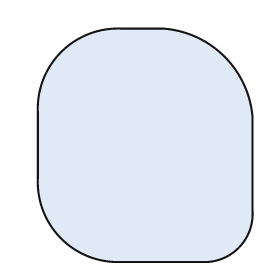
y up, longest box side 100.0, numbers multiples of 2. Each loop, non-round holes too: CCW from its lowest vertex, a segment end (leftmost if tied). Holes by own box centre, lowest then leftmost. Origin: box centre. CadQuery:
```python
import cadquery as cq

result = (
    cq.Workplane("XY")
    .moveTo(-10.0, -50.0)
    .lineTo(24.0, -50.0)
    .threePointArc((40.0, -44.0), (46.0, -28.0))
    .lineTo(46.0, 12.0)
    .threePointArc((34.0, 38.0), (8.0, 50.0))
    .lineTo(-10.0, 50.0)
    .threePointArc((-36.0, 40.0), (-46.0, 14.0))
    .lineTo(-46.0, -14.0)
    .threePointArc((-36.0, -40.0), (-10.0, -50.0))
    .close()
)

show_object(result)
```